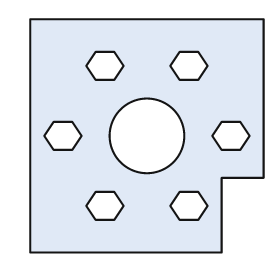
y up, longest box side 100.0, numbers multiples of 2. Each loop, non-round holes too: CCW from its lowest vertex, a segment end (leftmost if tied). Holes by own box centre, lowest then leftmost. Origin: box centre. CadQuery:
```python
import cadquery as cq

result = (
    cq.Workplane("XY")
    .moveTo(-50.0, -50.0)
    .lineTo(32.0, -50.0)
    .lineTo(32.0, -18.0)
    .lineTo(50.0, -18.0)
    .lineTo(50.0, 50.0)
    .lineTo(-50.0, 50.0)
    .close()
    .moveTo(-22.0, -36.0)
    .lineTo(-14.0, -36.0)
    .lineTo(-10.0, -30.0)
    .lineTo(-14.0, -24.0)
    .lineTo(-22.0, -24.0)
    .lineTo(-26.0, -30.0)
    .close()
    .moveTo(14.0, -36.0)
    .lineTo(22.0, -36.0)
    .lineTo(26.0, -30.0)
    .lineTo(22.0, -24.0)
    .lineTo(14.0, -24.0)
    .lineTo(10.0, -30.0)
    .close()
    .moveTo(-40.0, -6.0)
    .lineTo(-32.0, -6.0)
    .lineTo(-28.0, 0.0)
    .lineTo(-32.0, 6.0)
    .lineTo(-40.0, 6.0)
    .lineTo(-44.0, 0.0)
    .close()
    .moveTo(0.0, 0.0)
    .circle(16.0)
    .moveTo(32.0, -6.0)
    .lineTo(40.0, -6.0)
    .lineTo(44.0, 0.0)
    .lineTo(40.0, 6.0)
    .lineTo(32.0, 6.0)
    .lineTo(28.0, 0.0)
    .close()
    .moveTo(-22.0, 24.0)
    .lineTo(-14.0, 24.0)
    .lineTo(-10.0, 30.0)
    .lineTo(-14.0, 36.0)
    .lineTo(-22.0, 36.0)
    .lineTo(-26.0, 30.0)
    .close()
    .moveTo(14.0, 24.0)
    .lineTo(22.0, 24.0)
    .lineTo(26.0, 30.0)
    .lineTo(22.0, 36.0)
    .lineTo(14.0, 36.0)
    .lineTo(10.0, 30.0)
    .close()
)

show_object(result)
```